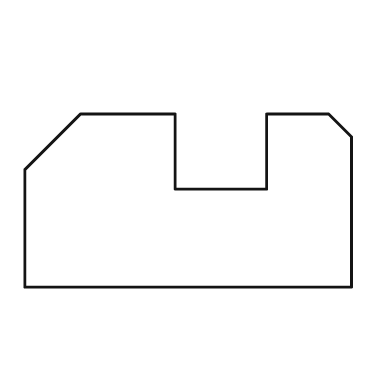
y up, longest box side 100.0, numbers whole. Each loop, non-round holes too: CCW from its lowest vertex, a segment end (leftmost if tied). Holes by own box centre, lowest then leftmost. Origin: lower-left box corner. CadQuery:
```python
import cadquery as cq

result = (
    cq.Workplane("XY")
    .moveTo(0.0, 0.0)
    .lineTo(100.0, 0.0)
    .lineTo(100.0, 46.0)
    .lineTo(93.0, 53.0)
    .lineTo(74.0, 53.0)
    .lineTo(74.0, 30.0)
    .lineTo(46.0, 30.0)
    .lineTo(46.0, 53.0)
    .lineTo(17.0, 53.0)
    .lineTo(0.0, 36.0)
    .close()
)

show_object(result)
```